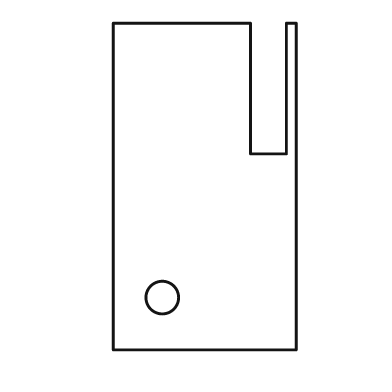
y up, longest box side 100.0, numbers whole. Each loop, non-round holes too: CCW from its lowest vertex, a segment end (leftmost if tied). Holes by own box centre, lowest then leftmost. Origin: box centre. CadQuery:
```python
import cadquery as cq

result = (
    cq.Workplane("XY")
    .moveTo(-28.0, -50.0)
    .lineTo(28.0, -50.0)
    .lineTo(28.0, 50.0)
    .lineTo(25.0, 50.0)
    .lineTo(25.0, 10.0)
    .lineTo(14.0, 10.0)
    .lineTo(14.0, 50.0)
    .lineTo(-28.0, 50.0)
    .close()
    .moveTo(-13.0, -34.0)
    .circle(5.0)
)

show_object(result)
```